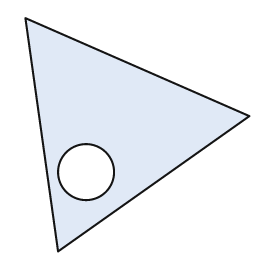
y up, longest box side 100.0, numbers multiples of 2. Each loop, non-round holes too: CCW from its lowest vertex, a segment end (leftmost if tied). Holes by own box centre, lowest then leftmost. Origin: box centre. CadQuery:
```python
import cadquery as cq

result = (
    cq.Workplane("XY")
    .moveTo(-34.0, -50.0)
    .lineTo(48.0, 8.0)
    .lineTo(-48.0, 50.0)
    .close()
    .moveTo(-22.0, -16.0)
    .circle(12.0)
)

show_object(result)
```